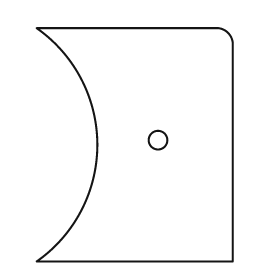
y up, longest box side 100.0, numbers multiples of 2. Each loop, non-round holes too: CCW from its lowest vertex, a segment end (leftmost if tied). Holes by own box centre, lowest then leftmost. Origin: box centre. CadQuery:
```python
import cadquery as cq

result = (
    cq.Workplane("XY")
    .moveTo(-42.0, -50.0)
    .lineTo(42.0, -50.0)
    .lineTo(42.0, 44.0)
    .threePointArc((40.0, 48.0), (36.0, 50.0))
    .lineTo(-42.0, 50.0)
    .threePointArc((-16.0, 0.0), (-42.0, -50.0))
    .close()
    .moveTo(10.0, 2.0)
    .circle(4.0)
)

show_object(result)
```